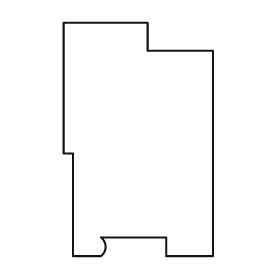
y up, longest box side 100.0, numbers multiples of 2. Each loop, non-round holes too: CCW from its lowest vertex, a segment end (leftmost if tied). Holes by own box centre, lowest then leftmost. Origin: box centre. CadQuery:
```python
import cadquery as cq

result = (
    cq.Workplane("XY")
    .moveTo(-28.0, -50.0)
    .lineTo(-16.0, -50.0)
    .threePointArc((-14.0, -46.0), (-16.0, -42.0))
    .lineTo(12.0, -42.0)
    .lineTo(12.0, -50.0)
    .lineTo(32.0, -50.0)
    .lineTo(32.0, 38.0)
    .lineTo(4.0, 38.0)
    .lineTo(4.0, 50.0)
    .lineTo(-32.0, 50.0)
    .lineTo(-32.0, -6.0)
    .lineTo(-28.0, -6.0)
    .close()
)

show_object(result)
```